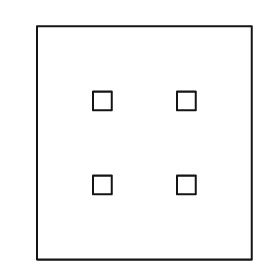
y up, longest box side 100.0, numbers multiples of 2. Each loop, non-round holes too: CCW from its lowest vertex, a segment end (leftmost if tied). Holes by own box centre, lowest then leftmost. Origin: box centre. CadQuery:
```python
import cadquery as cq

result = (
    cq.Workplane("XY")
    .moveTo(-46.0, -50.0)
    .lineTo(46.0, -50.0)
    .lineTo(46.0, 50.0)
    .lineTo(-46.0, 50.0)
    .close()
    .moveTo(-22.0, -22.0)
    .lineTo(-14.0, -22.0)
    .lineTo(-14.0, -14.0)
    .lineTo(-22.0, -14.0)
    .close()
    .moveTo(14.0, -22.0)
    .lineTo(22.0, -22.0)
    .lineTo(22.0, -14.0)
    .lineTo(14.0, -14.0)
    .close()
    .moveTo(-22.0, 14.0)
    .lineTo(-14.0, 14.0)
    .lineTo(-14.0, 22.0)
    .lineTo(-22.0, 22.0)
    .close()
    .moveTo(14.0, 14.0)
    .lineTo(22.0, 14.0)
    .lineTo(22.0, 22.0)
    .lineTo(14.0, 22.0)
    .close()
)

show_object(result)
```